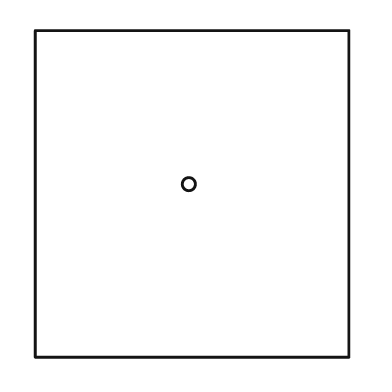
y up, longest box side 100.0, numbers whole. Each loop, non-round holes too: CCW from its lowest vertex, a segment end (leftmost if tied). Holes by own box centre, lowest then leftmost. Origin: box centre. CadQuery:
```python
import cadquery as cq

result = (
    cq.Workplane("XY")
    .moveTo(-48.0, -50.0)
    .lineTo(48.0, -50.0)
    .lineTo(48.0, 50.0)
    .lineTo(-48.0, 50.0)
    .close()
    .moveTo(-1.0, 3.0)
    .circle(2.0)
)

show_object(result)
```